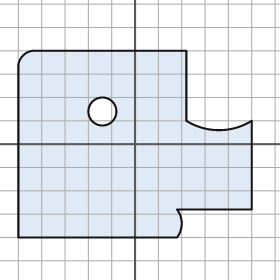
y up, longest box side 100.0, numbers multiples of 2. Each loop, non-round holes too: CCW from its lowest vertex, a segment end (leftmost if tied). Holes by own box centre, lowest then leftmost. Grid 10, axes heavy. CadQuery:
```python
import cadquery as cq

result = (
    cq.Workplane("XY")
    .moveTo(-50.0, -40.0)
    .lineTo(18.0, -40.0)
    .threePointArc((20.0, -34.0), (18.0, -28.0))
    .lineTo(50.0, -28.0)
    .lineTo(50.0, 10.0)
    .threePointArc((36.0, 6.0), (22.0, 10.0))
    .lineTo(22.0, 40.0)
    .lineTo(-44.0, 40.0)
    .threePointArc((-48.0, 38.0), (-50.0, 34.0))
    .close()
    .moveTo(-14.0, 14.0)
    .circle(6.0)
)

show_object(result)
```